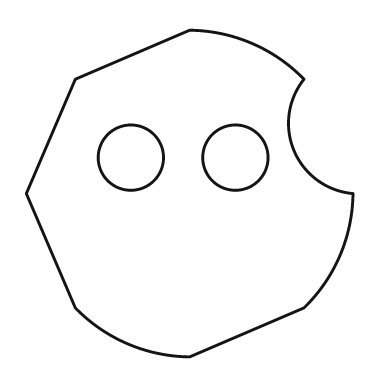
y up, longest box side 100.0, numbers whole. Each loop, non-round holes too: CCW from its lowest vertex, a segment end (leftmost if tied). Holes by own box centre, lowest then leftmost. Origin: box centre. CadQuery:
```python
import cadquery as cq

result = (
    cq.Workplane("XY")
    .moveTo(0.0, -50.0)
    .lineTo(35.0, -35.0)
    .threePointArc((46.0, -19.0), (50.0, 0.0))
    .threePointArc((32.0, 13.0), (35.0, 35.0))
    .threePointArc((19.0, 46.0), (0.0, 50.0))
    .lineTo(-35.0, 35.0)
    .lineTo(-50.0, 0.0)
    .lineTo(-35.0, -35.0)
    .threePointArc((-19.0, -46.0), (0.0, -50.0))
    .close()
    .moveTo(-18.0, 11.0)
    .circle(10.0)
    .moveTo(14.0, 11.0)
    .circle(10.0)
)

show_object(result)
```